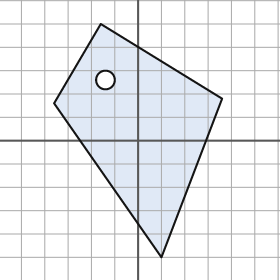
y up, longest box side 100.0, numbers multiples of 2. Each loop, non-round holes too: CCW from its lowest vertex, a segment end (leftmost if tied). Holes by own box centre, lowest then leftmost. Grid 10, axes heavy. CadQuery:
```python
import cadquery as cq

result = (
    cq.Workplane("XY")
    .moveTo(10.0, -50.0)
    .lineTo(36.0, 18.0)
    .lineTo(-16.0, 50.0)
    .lineTo(-36.0, 16.0)
    .close()
    .moveTo(-14.0, 26.0)
    .circle(4.0)
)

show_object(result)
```